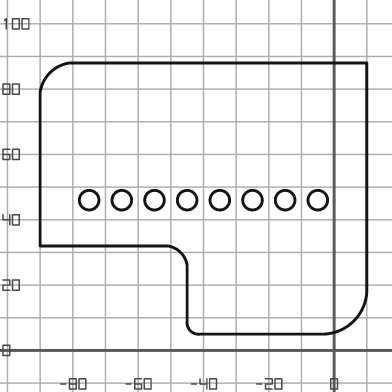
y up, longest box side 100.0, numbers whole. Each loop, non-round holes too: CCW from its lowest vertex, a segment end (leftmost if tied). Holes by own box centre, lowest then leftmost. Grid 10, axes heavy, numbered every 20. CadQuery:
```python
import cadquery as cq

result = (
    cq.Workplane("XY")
    .moveTo(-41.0, 5.0)
    .lineTo(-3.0, 5.0)
    .threePointArc((6.0, 9.0), (10.0, 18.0))
    .lineTo(10.0, 88.0)
    .lineTo(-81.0, 88.0)
    .threePointArc((-87.0, 85.0), (-90.0, 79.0))
    .lineTo(-90.0, 32.0)
    .lineTo(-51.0, 32.0)
    .threePointArc((-47.0, 30.0), (-45.0, 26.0))
    .lineTo(-45.0, 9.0)
    .threePointArc((-44.0, 6.0), (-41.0, 5.0))
    .close()
    .moveTo(-75.0, 46.0)
    .circle(3.0)
    .moveTo(-65.0, 46.0)
    .circle(3.0)
    .moveTo(-55.0, 46.0)
    .circle(3.0)
    .moveTo(-45.0, 46.0)
    .circle(3.0)
    .moveTo(-35.0, 46.0)
    .circle(3.0)
    .moveTo(-25.0, 46.0)
    .circle(3.0)
    .moveTo(-15.0, 46.0)
    .circle(3.0)
    .moveTo(-5.0, 46.0)
    .circle(3.0)
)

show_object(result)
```